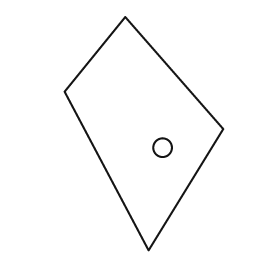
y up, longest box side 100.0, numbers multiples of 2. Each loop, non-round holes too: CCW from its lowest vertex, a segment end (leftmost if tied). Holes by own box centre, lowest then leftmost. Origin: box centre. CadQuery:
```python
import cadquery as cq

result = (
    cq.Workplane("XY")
    .moveTo(2.0, -50.0)
    .lineTo(34.0, 2.0)
    .lineTo(-8.0, 50.0)
    .lineTo(-34.0, 18.0)
    .close()
    .moveTo(8.0, -6.0)
    .circle(4.0)
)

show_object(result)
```